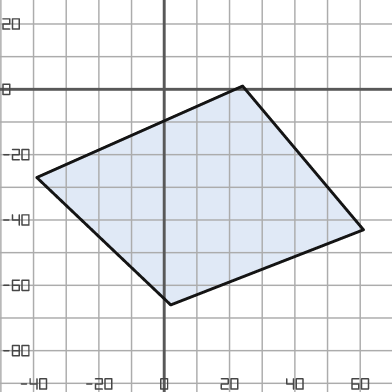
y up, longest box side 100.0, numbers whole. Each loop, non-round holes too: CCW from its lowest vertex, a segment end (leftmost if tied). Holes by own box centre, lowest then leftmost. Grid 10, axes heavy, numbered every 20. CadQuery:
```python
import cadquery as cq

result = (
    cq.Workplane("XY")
    .moveTo(2.0, -66.0)
    .lineTo(61.0, -43.0)
    .lineTo(24.0, 1.0)
    .lineTo(-39.0, -27.0)
    .close()
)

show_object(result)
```